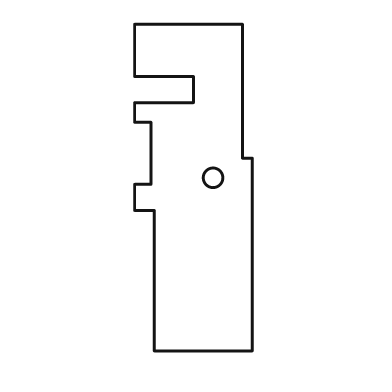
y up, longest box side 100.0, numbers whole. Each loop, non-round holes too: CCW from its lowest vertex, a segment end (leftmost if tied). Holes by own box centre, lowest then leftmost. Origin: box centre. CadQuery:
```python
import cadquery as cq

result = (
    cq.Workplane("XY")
    .moveTo(-12.0, -50.0)
    .lineTo(18.0, -50.0)
    .lineTo(18.0, 9.0)
    .lineTo(15.0, 9.0)
    .lineTo(15.0, 50.0)
    .lineTo(-18.0, 50.0)
    .lineTo(-18.0, 34.0)
    .lineTo(0.0, 34.0)
    .lineTo(0.0, 26.0)
    .lineTo(-18.0, 26.0)
    .lineTo(-18.0, 20.0)
    .lineTo(-13.0, 20.0)
    .lineTo(-13.0, 1.0)
    .lineTo(-18.0, 1.0)
    .lineTo(-18.0, -7.0)
    .lineTo(-12.0, -7.0)
    .close()
    .moveTo(6.0, 3.0)
    .circle(3.0)
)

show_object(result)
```